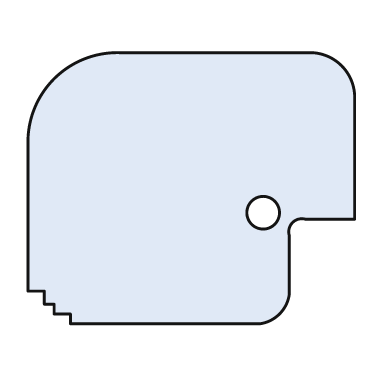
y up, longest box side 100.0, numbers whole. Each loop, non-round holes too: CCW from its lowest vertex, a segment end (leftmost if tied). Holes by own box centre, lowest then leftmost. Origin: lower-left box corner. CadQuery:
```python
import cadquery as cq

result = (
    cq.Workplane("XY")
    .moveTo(13.0, 0.0)
    .lineTo(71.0, 0.0)
    .threePointArc((77.0, 3.0), (80.0, 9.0))
    .lineTo(80.0, 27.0)
    .threePointArc((81.0, 31.0), (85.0, 32.0))
    .lineTo(100.0, 32.0)
    .lineTo(100.0, 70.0)
    .threePointArc((96.0, 79.0), (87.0, 83.0))
    .lineTo(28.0, 83.0)
    .threePointArc((8.0, 75.0), (0.0, 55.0))
    .lineTo(0.0, 10.0)
    .lineTo(5.0, 10.0)
    .lineTo(5.0, 6.0)
    .lineTo(8.0, 6.0)
    .lineTo(8.0, 3.0)
    .lineTo(13.0, 3.0)
    .close()
    .moveTo(72.0, 34.0)
    .circle(5.0)
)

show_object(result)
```